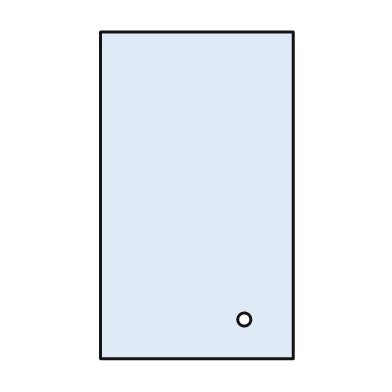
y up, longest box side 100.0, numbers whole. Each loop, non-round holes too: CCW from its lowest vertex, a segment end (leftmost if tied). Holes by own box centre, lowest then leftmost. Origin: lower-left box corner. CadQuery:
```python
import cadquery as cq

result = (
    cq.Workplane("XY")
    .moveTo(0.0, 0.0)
    .lineTo(59.0, 0.0)
    .lineTo(59.0, 100.0)
    .lineTo(0.0, 100.0)
    .close()
    .moveTo(44.0, 12.0)
    .circle(2.0)
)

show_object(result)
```